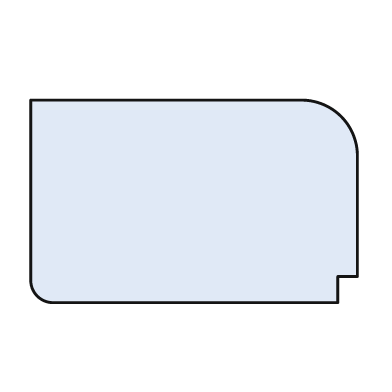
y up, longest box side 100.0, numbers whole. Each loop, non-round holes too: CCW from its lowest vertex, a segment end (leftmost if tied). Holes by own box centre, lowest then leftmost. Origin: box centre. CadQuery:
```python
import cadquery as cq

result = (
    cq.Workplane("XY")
    .moveTo(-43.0, -31.0)
    .lineTo(44.0, -31.0)
    .lineTo(44.0, -23.0)
    .lineTo(50.0, -23.0)
    .lineTo(50.0, 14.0)
    .threePointArc((45.0, 26.0), (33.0, 31.0))
    .lineTo(-50.0, 31.0)
    .lineTo(-50.0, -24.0)
    .threePointArc((-48.0, -29.0), (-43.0, -31.0))
    .close()
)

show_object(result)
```